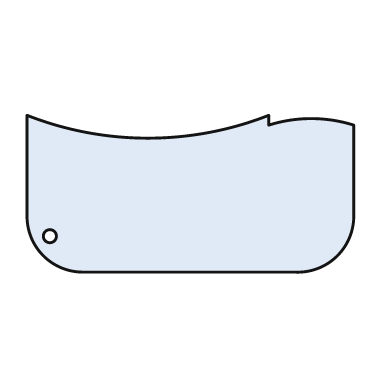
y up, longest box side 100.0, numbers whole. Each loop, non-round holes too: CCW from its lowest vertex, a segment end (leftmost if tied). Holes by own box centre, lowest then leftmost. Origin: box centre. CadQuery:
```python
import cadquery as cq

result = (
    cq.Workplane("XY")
    .moveTo(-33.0, -24.0)
    .lineTo(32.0, -24.0)
    .threePointArc((45.0, -19.0), (50.0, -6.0))
    .lineTo(50.0, 21.0)
    .threePointArc((37.0, 23.0), (24.0, 21.0))
    .lineTo(24.0, 24.0)
    .threePointArc((-13.0, 17.0), (-50.0, 24.0))
    .lineTo(-50.0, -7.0)
    .threePointArc((-45.0, -19.0), (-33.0, -24.0))
    .close()
    .moveTo(-43.0, -13.0)
    .circle(2.0)
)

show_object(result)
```